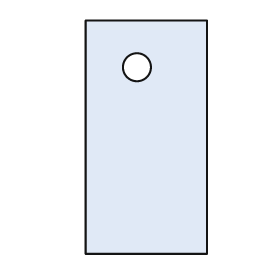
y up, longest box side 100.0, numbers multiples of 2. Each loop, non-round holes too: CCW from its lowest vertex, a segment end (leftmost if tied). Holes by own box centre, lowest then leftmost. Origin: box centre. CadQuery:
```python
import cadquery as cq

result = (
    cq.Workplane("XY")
    .moveTo(-26.0, -50.0)
    .lineTo(26.0, -50.0)
    .lineTo(26.0, 50.0)
    .lineTo(-26.0, 50.0)
    .close()
    .moveTo(-4.0, 30.0)
    .circle(6.0)
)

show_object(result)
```